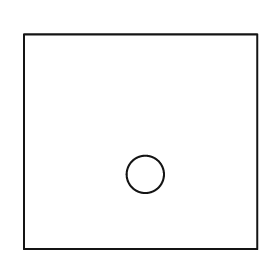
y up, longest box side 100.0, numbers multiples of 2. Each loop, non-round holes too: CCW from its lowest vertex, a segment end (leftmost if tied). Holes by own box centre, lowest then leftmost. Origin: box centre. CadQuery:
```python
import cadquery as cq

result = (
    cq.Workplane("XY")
    .moveTo(-50.0, -46.0)
    .lineTo(50.0, -46.0)
    .lineTo(50.0, 46.0)
    .lineTo(-50.0, 46.0)
    .close()
    .moveTo(2.0, -14.0)
    .circle(8.0)
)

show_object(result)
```